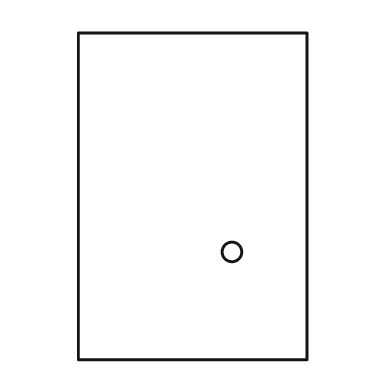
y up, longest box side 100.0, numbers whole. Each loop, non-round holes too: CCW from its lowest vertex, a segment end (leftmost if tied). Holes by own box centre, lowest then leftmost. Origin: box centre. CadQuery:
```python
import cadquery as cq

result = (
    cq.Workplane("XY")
    .moveTo(-35.0, -50.0)
    .lineTo(35.0, -50.0)
    .lineTo(35.0, 50.0)
    .lineTo(-35.0, 50.0)
    .close()
    .moveTo(12.0, -17.0)
    .circle(3.0)
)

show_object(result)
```